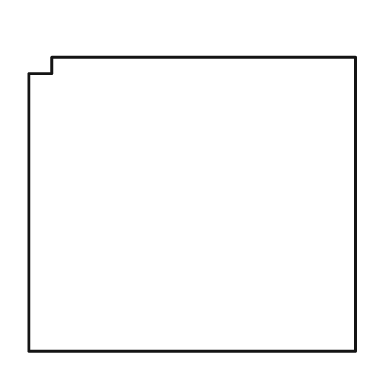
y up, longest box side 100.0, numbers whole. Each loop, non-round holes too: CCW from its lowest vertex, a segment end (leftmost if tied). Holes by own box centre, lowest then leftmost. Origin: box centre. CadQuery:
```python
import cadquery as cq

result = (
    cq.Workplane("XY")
    .moveTo(-50.0, -45.0)
    .lineTo(50.0, -45.0)
    .lineTo(50.0, 45.0)
    .lineTo(-43.0, 45.0)
    .lineTo(-43.0, 40.0)
    .lineTo(-50.0, 40.0)
    .close()
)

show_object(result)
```